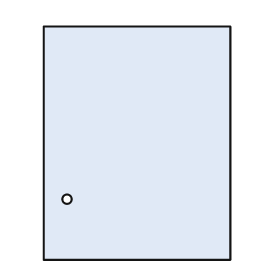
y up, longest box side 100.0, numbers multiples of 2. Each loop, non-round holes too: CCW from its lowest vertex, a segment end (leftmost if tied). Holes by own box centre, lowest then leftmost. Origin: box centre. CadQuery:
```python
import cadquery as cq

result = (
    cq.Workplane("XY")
    .moveTo(-40.0, -50.0)
    .lineTo(40.0, -50.0)
    .lineTo(40.0, 50.0)
    .lineTo(-40.0, 50.0)
    .close()
    .moveTo(-30.0, -24.0)
    .circle(2.0)
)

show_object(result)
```